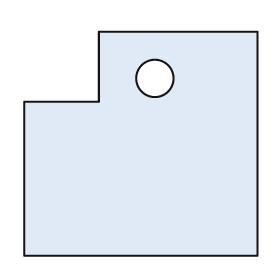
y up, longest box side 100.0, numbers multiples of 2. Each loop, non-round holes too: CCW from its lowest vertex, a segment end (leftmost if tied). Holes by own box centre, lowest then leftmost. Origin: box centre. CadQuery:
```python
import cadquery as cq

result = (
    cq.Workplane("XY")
    .moveTo(-50.0, -48.0)
    .lineTo(50.0, -48.0)
    .lineTo(50.0, 48.0)
    .lineTo(-18.0, 48.0)
    .lineTo(-18.0, 18.0)
    .lineTo(-50.0, 18.0)
    .close()
    .moveTo(6.0, 28.0)
    .circle(8.0)
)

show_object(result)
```